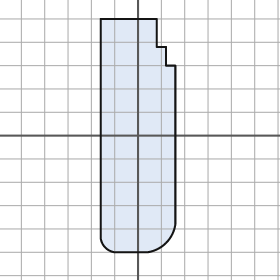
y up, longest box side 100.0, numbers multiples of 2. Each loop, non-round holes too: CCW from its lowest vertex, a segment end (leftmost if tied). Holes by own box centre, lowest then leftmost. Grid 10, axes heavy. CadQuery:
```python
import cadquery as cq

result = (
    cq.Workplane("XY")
    .moveTo(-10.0, -50.0)
    .lineTo(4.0, -50.0)
    .threePointArc((12.0, -46.0), (16.0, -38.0))
    .lineTo(16.0, 30.0)
    .lineTo(12.0, 30.0)
    .lineTo(12.0, 38.0)
    .lineTo(8.0, 38.0)
    .lineTo(8.0, 50.0)
    .lineTo(-16.0, 50.0)
    .lineTo(-16.0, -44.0)
    .threePointArc((-14.0, -48.0), (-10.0, -50.0))
    .close()
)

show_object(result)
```